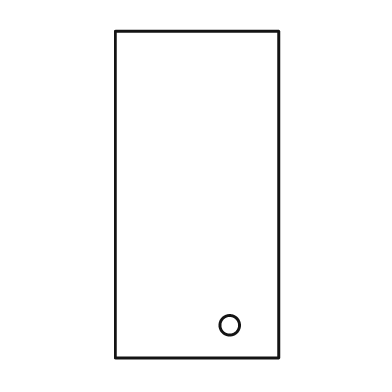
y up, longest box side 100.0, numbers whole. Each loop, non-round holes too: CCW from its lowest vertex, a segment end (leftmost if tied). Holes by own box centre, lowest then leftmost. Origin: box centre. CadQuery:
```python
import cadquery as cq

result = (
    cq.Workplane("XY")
    .moveTo(-25.0, -50.0)
    .lineTo(25.0, -50.0)
    .lineTo(25.0, 50.0)
    .lineTo(-25.0, 50.0)
    .close()
    .moveTo(10.0, -40.0)
    .circle(3.0)
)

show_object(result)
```